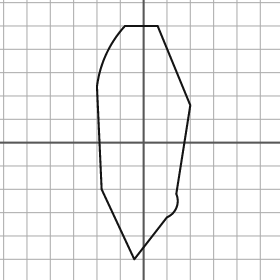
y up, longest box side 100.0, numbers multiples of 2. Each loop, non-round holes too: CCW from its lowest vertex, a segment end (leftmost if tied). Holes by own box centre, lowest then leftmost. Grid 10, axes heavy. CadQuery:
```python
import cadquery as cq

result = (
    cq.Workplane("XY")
    .moveTo(-4.0, -50.0)
    .lineTo(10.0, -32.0)
    .threePointArc((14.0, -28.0), (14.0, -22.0))
    .lineTo(20.0, 16.0)
    .lineTo(6.0, 50.0)
    .lineTo(-8.0, 50.0)
    .threePointArc((-16.0, 38.0), (-20.0, 24.0))
    .lineTo(-18.0, -20.0)
    .close()
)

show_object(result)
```